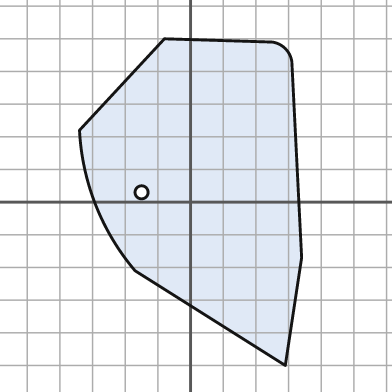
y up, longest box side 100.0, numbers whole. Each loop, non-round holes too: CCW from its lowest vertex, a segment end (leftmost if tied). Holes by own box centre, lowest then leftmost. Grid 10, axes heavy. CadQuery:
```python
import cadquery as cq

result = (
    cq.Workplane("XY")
    .moveTo(29.0, -50.0)
    .lineTo(34.0, -17.0)
    .lineTo(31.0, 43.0)
    .threePointArc((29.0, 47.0), (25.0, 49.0))
    .lineTo(-8.0, 50.0)
    .lineTo(-34.0, 22.0)
    .threePointArc((-29.0, -1.0), (-17.0, -21.0))
    .close()
    .moveTo(-15.0, 3.0)
    .circle(2.0)
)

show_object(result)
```